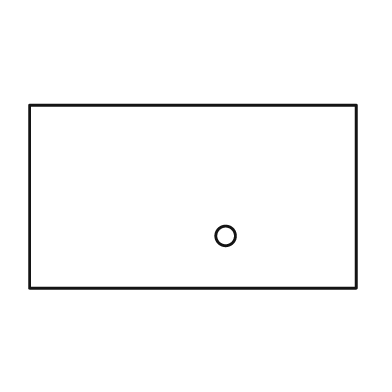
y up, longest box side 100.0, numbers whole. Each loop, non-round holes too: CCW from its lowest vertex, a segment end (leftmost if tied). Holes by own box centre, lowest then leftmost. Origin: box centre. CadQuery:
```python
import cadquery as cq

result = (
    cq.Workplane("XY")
    .moveTo(-50.0, -28.0)
    .lineTo(50.0, -28.0)
    .lineTo(50.0, 28.0)
    .lineTo(-50.0, 28.0)
    .close()
    .moveTo(10.0, -12.0)
    .circle(3.0)
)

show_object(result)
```